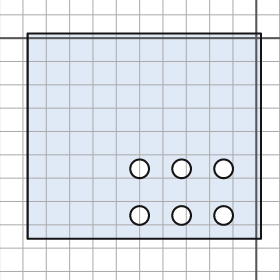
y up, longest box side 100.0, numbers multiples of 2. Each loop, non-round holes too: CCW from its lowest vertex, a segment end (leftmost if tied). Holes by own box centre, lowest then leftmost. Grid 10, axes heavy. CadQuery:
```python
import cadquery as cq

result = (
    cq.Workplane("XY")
    .moveTo(-98.0, -86.0)
    .lineTo(2.0, -86.0)
    .lineTo(2.0, 2.0)
    .lineTo(-98.0, 2.0)
    .close()
    .moveTo(-50.0, -76.0)
    .circle(4.0)
    .moveTo(-32.0, -76.0)
    .circle(4.0)
    .moveTo(-14.0, -76.0)
    .circle(4.0)
    .moveTo(-50.0, -56.0)
    .circle(4.0)
    .moveTo(-32.0, -56.0)
    .circle(4.0)
    .moveTo(-14.0, -56.0)
    .circle(4.0)
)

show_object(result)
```